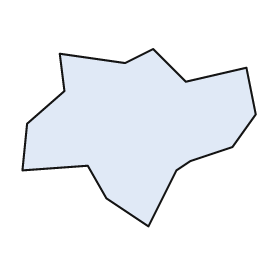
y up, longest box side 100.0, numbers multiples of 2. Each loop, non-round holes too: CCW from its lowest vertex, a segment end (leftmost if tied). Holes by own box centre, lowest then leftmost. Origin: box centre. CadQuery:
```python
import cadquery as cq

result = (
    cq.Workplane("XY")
    .moveTo(4.0, -38.0)
    .lineTo(16.0, -14.0)
    .lineTo(22.0, -10.0)
    .lineTo(40.0, -4.0)
    .lineTo(50.0, 10.0)
    .lineTo(46.0, 30.0)
    .lineTo(20.0, 24.0)
    .lineTo(6.0, 38.0)
    .lineTo(-6.0, 32.0)
    .lineTo(-34.0, 36.0)
    .lineTo(-32.0, 20.0)
    .lineTo(-48.0, 6.0)
    .lineTo(-50.0, -14.0)
    .lineTo(-22.0, -12.0)
    .lineTo(-14.0, -26.0)
    .close()
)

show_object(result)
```